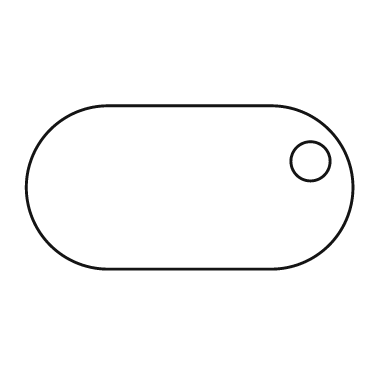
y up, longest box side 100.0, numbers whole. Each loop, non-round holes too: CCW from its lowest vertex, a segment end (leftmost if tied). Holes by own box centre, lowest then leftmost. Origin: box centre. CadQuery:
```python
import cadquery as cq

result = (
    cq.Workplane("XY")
    .moveTo(-25.0, -25.0)
    .lineTo(25.0, -25.0)
    .threePointArc((50.0, 0.0), (25.0, 25.0))
    .lineTo(-25.0, 25.0)
    .threePointArc((-50.0, 0.0), (-25.0, -25.0))
    .close()
    .moveTo(37.0, 8.0)
    .circle(6.0)
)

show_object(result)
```